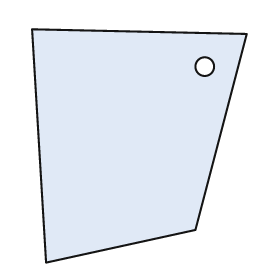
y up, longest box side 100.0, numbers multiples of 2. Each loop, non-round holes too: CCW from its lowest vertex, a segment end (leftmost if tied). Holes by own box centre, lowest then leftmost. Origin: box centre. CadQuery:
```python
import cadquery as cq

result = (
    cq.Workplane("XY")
    .moveTo(-40.0, -50.0)
    .lineTo(24.0, -36.0)
    .lineTo(46.0, 48.0)
    .lineTo(-46.0, 50.0)
    .close()
    .moveTo(28.0, 34.0)
    .circle(4.0)
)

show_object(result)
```